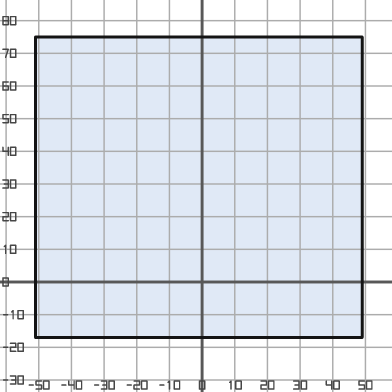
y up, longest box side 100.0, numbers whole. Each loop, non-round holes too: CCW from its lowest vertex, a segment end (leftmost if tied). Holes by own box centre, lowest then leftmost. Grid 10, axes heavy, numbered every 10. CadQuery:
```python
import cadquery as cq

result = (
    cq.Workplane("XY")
    .moveTo(-51.0, -17.0)
    .lineTo(49.0, -17.0)
    .lineTo(49.0, 75.0)
    .lineTo(-51.0, 75.0)
    .close()
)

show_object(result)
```